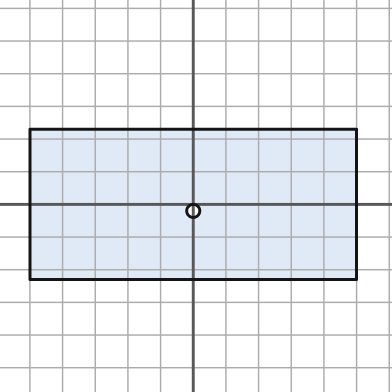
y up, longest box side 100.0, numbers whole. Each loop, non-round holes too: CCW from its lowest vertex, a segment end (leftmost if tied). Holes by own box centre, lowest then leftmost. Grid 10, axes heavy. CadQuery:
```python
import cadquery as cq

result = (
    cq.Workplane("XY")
    .moveTo(-50.0, -23.0)
    .lineTo(50.0, -23.0)
    .lineTo(50.0, 23.0)
    .lineTo(-50.0, 23.0)
    .close()
    .moveTo(0.0, -2.0)
    .circle(2.0)
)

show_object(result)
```